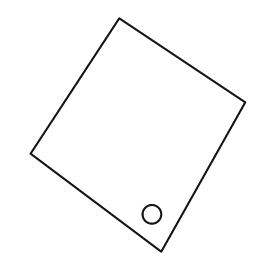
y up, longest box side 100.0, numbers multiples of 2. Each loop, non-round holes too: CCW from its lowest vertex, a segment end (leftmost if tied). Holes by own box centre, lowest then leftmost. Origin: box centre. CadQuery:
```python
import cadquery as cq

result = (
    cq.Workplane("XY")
    .moveTo(10.0, -50.0)
    .lineTo(46.0, 14.0)
    .lineTo(-8.0, 50.0)
    .lineTo(-46.0, -8.0)
    .close()
    .moveTo(6.0, -34.0)
    .circle(4.0)
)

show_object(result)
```